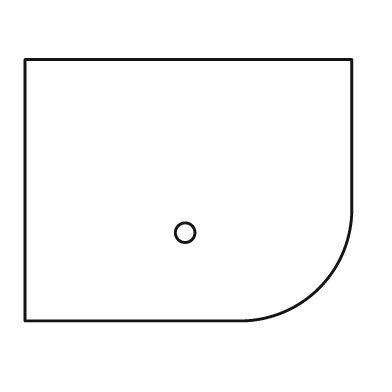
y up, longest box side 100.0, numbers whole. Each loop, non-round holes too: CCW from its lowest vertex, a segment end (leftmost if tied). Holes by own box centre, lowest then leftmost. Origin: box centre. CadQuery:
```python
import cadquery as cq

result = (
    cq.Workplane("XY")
    .moveTo(-50.0, -40.0)
    .lineTo(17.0, -40.0)
    .threePointArc((40.0, -30.0), (50.0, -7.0))
    .lineTo(50.0, 40.0)
    .lineTo(-50.0, 40.0)
    .close()
    .moveTo(-1.0, -13.0)
    .circle(3.0)
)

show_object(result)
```